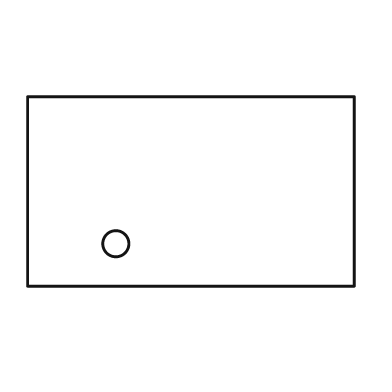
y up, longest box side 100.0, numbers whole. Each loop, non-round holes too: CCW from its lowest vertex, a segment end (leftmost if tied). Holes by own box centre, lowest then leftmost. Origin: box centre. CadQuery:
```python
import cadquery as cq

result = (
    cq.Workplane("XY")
    .moveTo(-50.0, -29.0)
    .lineTo(50.0, -29.0)
    .lineTo(50.0, 29.0)
    .lineTo(-50.0, 29.0)
    .close()
    .moveTo(-23.0, -16.0)
    .circle(4.0)
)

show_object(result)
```